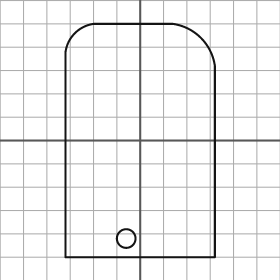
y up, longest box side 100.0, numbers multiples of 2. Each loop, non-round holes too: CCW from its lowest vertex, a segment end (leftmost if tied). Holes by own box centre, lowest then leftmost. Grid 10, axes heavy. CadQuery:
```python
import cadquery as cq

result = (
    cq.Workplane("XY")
    .moveTo(-32.0, -50.0)
    .lineTo(32.0, -50.0)
    .lineTo(32.0, 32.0)
    .threePointArc((26.0, 44.0), (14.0, 50.0))
    .lineTo(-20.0, 50.0)
    .threePointArc((-28.0, 46.0), (-32.0, 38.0))
    .close()
    .moveTo(-6.0, -42.0)
    .circle(4.0)
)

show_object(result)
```